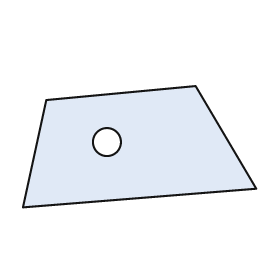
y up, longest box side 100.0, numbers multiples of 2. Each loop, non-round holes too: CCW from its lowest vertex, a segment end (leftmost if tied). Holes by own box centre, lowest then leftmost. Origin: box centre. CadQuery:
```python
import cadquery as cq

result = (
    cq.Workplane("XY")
    .moveTo(-50.0, -26.0)
    .lineTo(50.0, -18.0)
    .lineTo(24.0, 26.0)
    .lineTo(-40.0, 20.0)
    .close()
    .moveTo(-14.0, 2.0)
    .circle(6.0)
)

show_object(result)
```